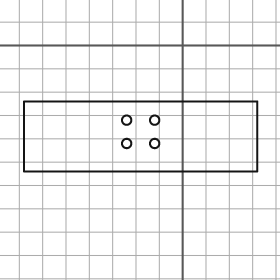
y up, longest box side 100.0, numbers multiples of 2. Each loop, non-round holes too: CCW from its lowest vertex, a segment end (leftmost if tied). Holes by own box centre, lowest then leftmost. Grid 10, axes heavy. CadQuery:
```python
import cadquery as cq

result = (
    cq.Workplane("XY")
    .moveTo(-68.0, -54.0)
    .lineTo(32.0, -54.0)
    .lineTo(32.0, -24.0)
    .lineTo(-68.0, -24.0)
    .close()
    .moveTo(-24.0, -42.0)
    .circle(2.0)
    .moveTo(-12.0, -42.0)
    .circle(2.0)
    .moveTo(-24.0, -32.0)
    .circle(2.0)
    .moveTo(-12.0, -32.0)
    .circle(2.0)
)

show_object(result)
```